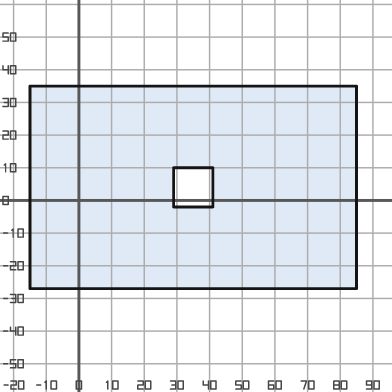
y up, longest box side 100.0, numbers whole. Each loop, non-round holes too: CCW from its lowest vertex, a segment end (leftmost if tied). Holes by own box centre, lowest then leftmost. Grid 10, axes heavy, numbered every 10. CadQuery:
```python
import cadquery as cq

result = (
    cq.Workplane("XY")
    .moveTo(-15.0, -27.0)
    .lineTo(85.0, -27.0)
    .lineTo(85.0, 35.0)
    .lineTo(-15.0, 35.0)
    .close()
    .moveTo(29.0, -2.0)
    .lineTo(41.0, -2.0)
    .lineTo(41.0, 10.0)
    .lineTo(29.0, 10.0)
    .close()
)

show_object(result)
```